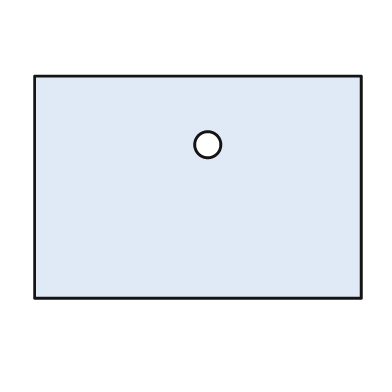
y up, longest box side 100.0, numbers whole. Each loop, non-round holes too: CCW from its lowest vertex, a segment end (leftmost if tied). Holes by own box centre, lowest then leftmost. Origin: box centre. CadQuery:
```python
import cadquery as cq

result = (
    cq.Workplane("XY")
    .moveTo(-50.0, -34.0)
    .lineTo(50.0, -34.0)
    .lineTo(50.0, 34.0)
    .lineTo(-50.0, 34.0)
    .close()
    .moveTo(3.0, 13.0)
    .circle(4.0)
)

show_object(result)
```